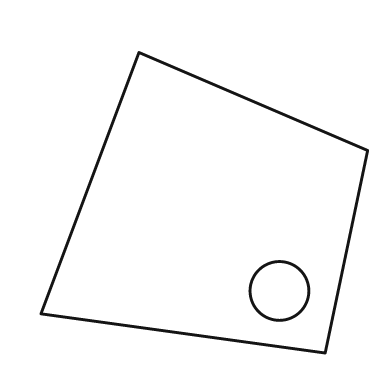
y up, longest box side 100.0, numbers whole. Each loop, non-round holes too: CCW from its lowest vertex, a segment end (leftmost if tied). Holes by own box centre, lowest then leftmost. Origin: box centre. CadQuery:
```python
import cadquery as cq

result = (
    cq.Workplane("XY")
    .moveTo(37.0, -46.0)
    .lineTo(50.0, 16.0)
    .lineTo(-20.0, 46.0)
    .lineTo(-50.0, -34.0)
    .close()
    .moveTo(23.0, -27.0)
    .circle(9.0)
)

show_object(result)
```